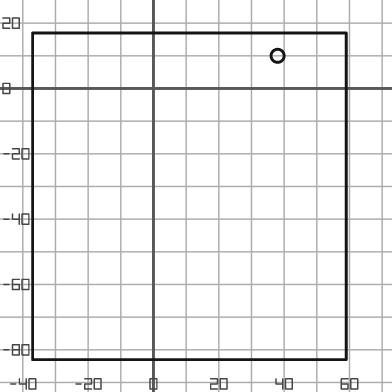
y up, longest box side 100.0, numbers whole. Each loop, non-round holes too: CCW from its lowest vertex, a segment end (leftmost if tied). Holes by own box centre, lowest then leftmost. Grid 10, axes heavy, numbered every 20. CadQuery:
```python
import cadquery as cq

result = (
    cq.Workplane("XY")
    .moveTo(-37.0, -83.0)
    .lineTo(59.0, -83.0)
    .lineTo(59.0, 17.0)
    .lineTo(-37.0, 17.0)
    .close()
    .moveTo(38.0, 10.0)
    .circle(2.0)
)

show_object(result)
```